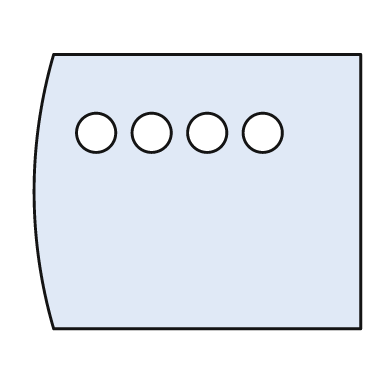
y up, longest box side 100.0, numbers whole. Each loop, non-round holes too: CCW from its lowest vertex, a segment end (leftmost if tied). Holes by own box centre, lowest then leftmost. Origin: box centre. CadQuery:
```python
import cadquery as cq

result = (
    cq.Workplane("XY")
    .moveTo(-44.0, -42.0)
    .lineTo(50.0, -42.0)
    .lineTo(50.0, 42.0)
    .lineTo(-44.0, 42.0)
    .threePointArc((-50.0, 0.0), (-44.0, -42.0))
    .close()
    .moveTo(-31.0, 18.0)
    .circle(6.0)
    .moveTo(-14.0, 18.0)
    .circle(6.0)
    .moveTo(3.0, 18.0)
    .circle(6.0)
    .moveTo(20.0, 18.0)
    .circle(6.0)
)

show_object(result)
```